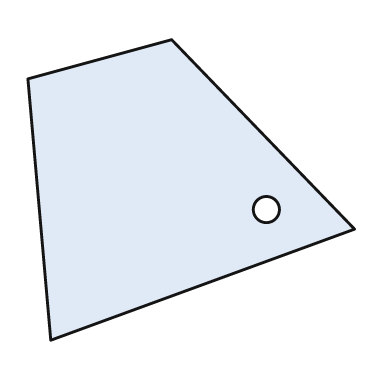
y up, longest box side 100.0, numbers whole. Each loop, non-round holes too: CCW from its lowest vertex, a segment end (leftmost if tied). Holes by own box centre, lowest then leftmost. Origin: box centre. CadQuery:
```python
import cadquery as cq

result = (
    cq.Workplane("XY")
    .moveTo(-43.0, -46.0)
    .lineTo(50.0, -12.0)
    .lineTo(-6.0, 46.0)
    .lineTo(-50.0, 34.0)
    .close()
    .moveTo(23.0, -6.0)
    .circle(4.0)
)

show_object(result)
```